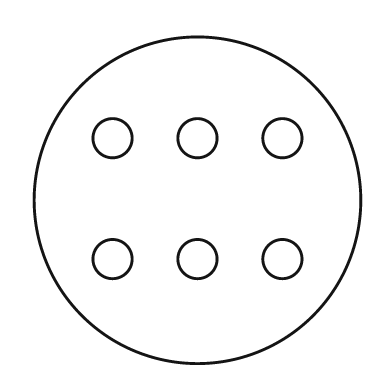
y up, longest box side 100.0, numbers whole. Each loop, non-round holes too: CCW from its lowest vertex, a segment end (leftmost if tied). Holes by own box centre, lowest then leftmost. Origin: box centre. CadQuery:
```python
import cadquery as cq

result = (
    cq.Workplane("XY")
    .moveTo(0.0, 0.0)
    .circle(50.0)
    .moveTo(-26.0, -18.0)
    .circle(6.0)
    .moveTo(0.0, -18.0)
    .circle(6.0)
    .moveTo(26.0, -18.0)
    .circle(6.0)
    .moveTo(-26.0, 19.0)
    .circle(6.0)
    .moveTo(0.0, 19.0)
    .circle(6.0)
    .moveTo(26.0, 19.0)
    .circle(6.0)
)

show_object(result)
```